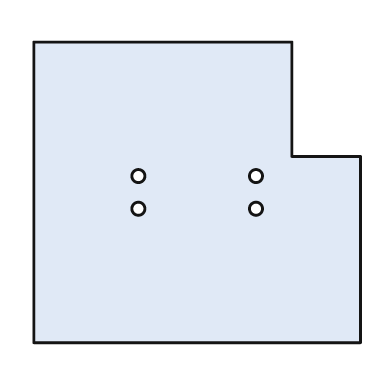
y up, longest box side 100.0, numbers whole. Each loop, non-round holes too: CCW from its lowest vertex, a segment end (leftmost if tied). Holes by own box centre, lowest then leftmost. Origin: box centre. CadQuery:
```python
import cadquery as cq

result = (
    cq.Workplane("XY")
    .moveTo(-50.0, -46.0)
    .lineTo(50.0, -46.0)
    .lineTo(50.0, 11.0)
    .lineTo(29.0, 11.0)
    .lineTo(29.0, 46.0)
    .lineTo(-50.0, 46.0)
    .close()
    .moveTo(-18.0, -5.0)
    .circle(2.0)
    .moveTo(18.0, -5.0)
    .circle(2.0)
    .moveTo(-18.0, 5.0)
    .circle(2.0)
    .moveTo(18.0, 5.0)
    .circle(2.0)
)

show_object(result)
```